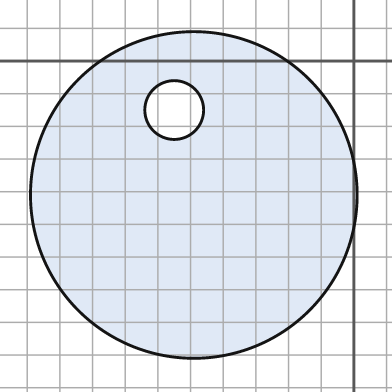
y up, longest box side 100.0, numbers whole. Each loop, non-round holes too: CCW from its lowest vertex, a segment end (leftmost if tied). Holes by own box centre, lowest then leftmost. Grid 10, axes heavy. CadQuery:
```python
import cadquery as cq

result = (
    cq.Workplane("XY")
    .moveTo(-49.0, -41.0)
    .circle(50.0)
    .moveTo(-55.0, -15.0)
    .circle(9.0)
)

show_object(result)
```